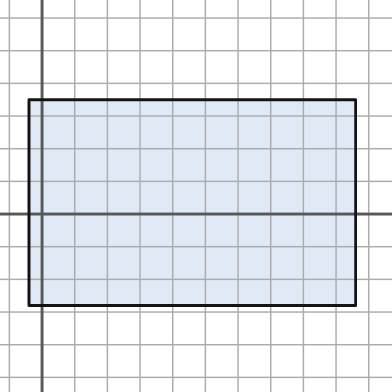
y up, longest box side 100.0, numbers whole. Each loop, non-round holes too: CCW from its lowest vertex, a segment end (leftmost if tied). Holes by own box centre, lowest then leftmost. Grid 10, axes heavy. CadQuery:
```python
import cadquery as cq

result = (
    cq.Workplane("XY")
    .moveTo(-4.0, -28.0)
    .lineTo(96.0, -28.0)
    .lineTo(96.0, 35.0)
    .lineTo(-4.0, 35.0)
    .close()
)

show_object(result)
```